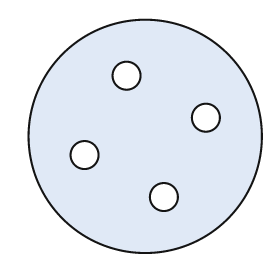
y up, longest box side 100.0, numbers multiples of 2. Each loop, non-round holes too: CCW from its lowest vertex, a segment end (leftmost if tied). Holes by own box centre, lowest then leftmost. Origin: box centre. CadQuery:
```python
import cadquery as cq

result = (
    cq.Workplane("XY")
    .moveTo(0.0, 0.0)
    .circle(50.0)
    .moveTo(8.0, -26.0)
    .circle(6.0)
    .moveTo(-26.0, -8.0)
    .circle(6.0)
    .moveTo(26.0, 8.0)
    .circle(6.0)
    .moveTo(-8.0, 26.0)
    .circle(6.0)
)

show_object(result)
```